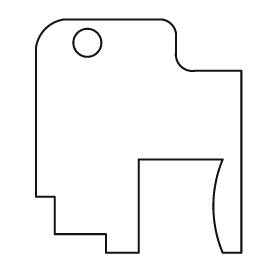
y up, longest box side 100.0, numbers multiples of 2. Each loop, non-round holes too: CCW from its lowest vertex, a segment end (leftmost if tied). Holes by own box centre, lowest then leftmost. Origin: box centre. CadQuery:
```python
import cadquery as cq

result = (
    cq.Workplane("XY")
    .moveTo(-14.0, -50.0)
    .lineTo(0.0, -50.0)
    .lineTo(0.0, -10.0)
    .lineTo(36.0, -10.0)
    .threePointArc((32.0, -30.0), (36.0, -50.0))
    .lineTo(44.0, -50.0)
    .lineTo(44.0, 28.0)
    .lineTo(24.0, 28.0)
    .threePointArc((18.0, 30.0), (16.0, 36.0))
    .lineTo(16.0, 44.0)
    .threePointArc((14.0, 48.0), (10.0, 50.0))
    .lineTo(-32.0, 50.0)
    .threePointArc((-40.0, 46.0), (-44.0, 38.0))
    .lineTo(-44.0, -26.0)
    .lineTo(-36.0, -26.0)
    .lineTo(-36.0, -42.0)
    .lineTo(-14.0, -42.0)
    .close()
    .moveTo(-22.0, 40.0)
    .circle(6.0)
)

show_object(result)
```